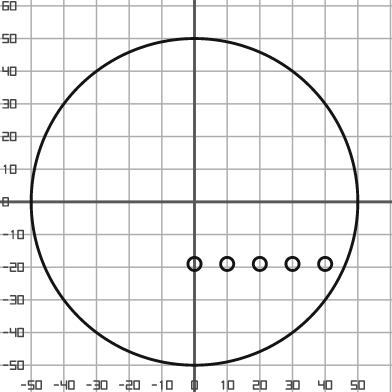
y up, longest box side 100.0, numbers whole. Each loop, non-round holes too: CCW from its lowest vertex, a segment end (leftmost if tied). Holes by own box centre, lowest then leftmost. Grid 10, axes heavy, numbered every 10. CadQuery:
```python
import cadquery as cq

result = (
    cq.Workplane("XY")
    .moveTo(0.0, 0.0)
    .circle(50.0)
    .moveTo(0.0, -19.0)
    .circle(2.0)
    .moveTo(10.0, -19.0)
    .circle(2.0)
    .moveTo(20.0, -19.0)
    .circle(2.0)
    .moveTo(30.0, -19.0)
    .circle(2.0)
    .moveTo(40.0, -19.0)
    .circle(2.0)
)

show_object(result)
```